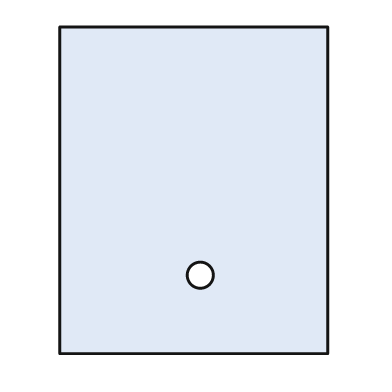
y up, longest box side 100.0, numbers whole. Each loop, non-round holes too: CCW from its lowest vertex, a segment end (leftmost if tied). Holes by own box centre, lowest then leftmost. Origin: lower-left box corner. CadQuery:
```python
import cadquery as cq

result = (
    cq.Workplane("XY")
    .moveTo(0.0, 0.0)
    .lineTo(82.0, 0.0)
    .lineTo(82.0, 100.0)
    .lineTo(0.0, 100.0)
    .close()
    .moveTo(43.0, 24.0)
    .circle(4.0)
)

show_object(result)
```